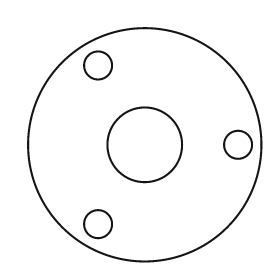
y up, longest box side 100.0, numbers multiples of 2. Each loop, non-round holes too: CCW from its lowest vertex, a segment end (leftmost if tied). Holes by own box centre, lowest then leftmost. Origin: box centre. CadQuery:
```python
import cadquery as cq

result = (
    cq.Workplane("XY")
    .moveTo(0.0, 0.0)
    .circle(50.0)
    .moveTo(-20.0, -34.0)
    .circle(6.0)
    .moveTo(0.0, 0.0)
    .circle(16.0)
    .moveTo(40.0, 0.0)
    .circle(6.0)
    .moveTo(-20.0, 34.0)
    .circle(6.0)
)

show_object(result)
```